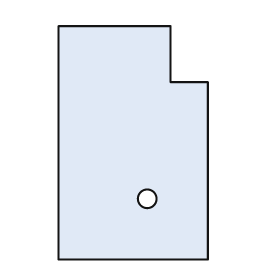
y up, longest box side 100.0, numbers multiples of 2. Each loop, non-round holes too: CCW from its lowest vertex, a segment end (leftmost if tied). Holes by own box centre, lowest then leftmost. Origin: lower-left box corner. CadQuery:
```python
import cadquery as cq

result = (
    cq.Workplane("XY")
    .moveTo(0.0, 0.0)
    .lineTo(64.0, 0.0)
    .lineTo(64.0, 76.0)
    .lineTo(48.0, 76.0)
    .lineTo(48.0, 100.0)
    .lineTo(0.0, 100.0)
    .close()
    .moveTo(38.0, 26.0)
    .circle(4.0)
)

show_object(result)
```